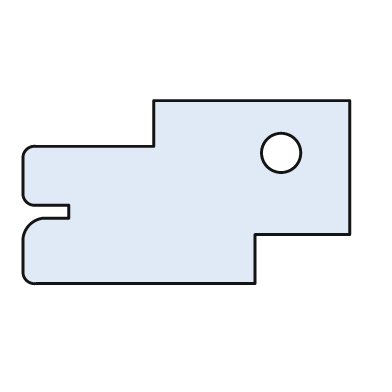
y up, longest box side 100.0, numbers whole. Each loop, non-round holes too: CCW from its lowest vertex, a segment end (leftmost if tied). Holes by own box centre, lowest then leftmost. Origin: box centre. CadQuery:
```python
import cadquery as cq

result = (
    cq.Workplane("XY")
    .moveTo(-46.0, -28.0)
    .lineTo(21.0, -28.0)
    .lineTo(21.0, -13.0)
    .lineTo(50.0, -13.0)
    .lineTo(50.0, 28.0)
    .lineTo(-10.0, 28.0)
    .lineTo(-10.0, 14.0)
    .lineTo(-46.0, 14.0)
    .threePointArc((-49.0, 13.0), (-50.0, 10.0))
    .lineTo(-50.0, 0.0)
    .threePointArc((-49.0, -3.0), (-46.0, -4.0))
    .lineTo(-36.0, -4.0)
    .lineTo(-36.0, -8.0)
    .lineTo(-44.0, -8.0)
    .threePointArc((-48.0, -10.0), (-50.0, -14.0))
    .lineTo(-50.0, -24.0)
    .threePointArc((-49.0, -27.0), (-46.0, -28.0))
    .close()
    .moveTo(29.0, 12.0)
    .circle(6.0)
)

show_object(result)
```